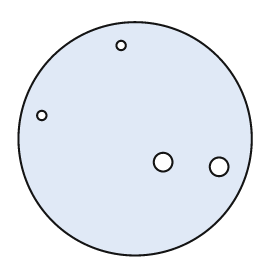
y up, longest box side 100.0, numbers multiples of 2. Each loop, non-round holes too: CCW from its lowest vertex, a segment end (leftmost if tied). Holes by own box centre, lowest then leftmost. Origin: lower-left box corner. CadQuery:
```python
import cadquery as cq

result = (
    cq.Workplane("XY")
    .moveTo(50.0, 50.0)
    .circle(50.0)
    .moveTo(86.0, 38.0)
    .circle(4.0)
    .moveTo(62.0, 40.0)
    .circle(4.0)
    .moveTo(10.0, 60.0)
    .circle(2.0)
    .moveTo(44.0, 90.0)
    .circle(2.0)
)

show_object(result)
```